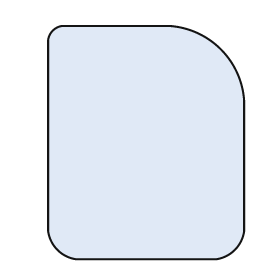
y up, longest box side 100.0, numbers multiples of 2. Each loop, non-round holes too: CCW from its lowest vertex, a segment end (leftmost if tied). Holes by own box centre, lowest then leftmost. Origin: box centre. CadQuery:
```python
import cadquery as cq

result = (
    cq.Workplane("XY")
    .moveTo(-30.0, -50.0)
    .lineTo(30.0, -50.0)
    .threePointArc((38.0, -46.0), (42.0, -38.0))
    .lineTo(42.0, 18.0)
    .threePointArc((32.0, 40.0), (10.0, 50.0))
    .lineTo(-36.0, 50.0)
    .threePointArc((-40.0, 48.0), (-42.0, 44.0))
    .lineTo(-42.0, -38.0)
    .threePointArc((-38.0, -46.0), (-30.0, -50.0))
    .close()
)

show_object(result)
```